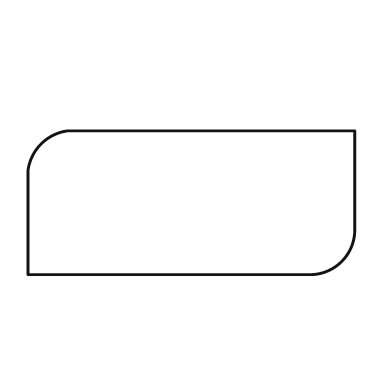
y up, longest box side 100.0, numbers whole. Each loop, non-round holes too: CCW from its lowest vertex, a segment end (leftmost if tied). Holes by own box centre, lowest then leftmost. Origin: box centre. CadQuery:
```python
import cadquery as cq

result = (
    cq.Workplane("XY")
    .moveTo(-50.0, -22.0)
    .lineTo(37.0, -22.0)
    .threePointArc((46.0, -18.0), (50.0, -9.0))
    .lineTo(50.0, 22.0)
    .lineTo(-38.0, 22.0)
    .threePointArc((-46.0, 18.0), (-50.0, 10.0))
    .close()
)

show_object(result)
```